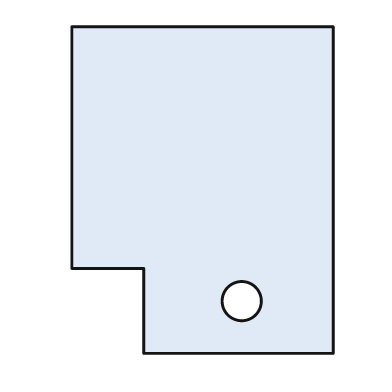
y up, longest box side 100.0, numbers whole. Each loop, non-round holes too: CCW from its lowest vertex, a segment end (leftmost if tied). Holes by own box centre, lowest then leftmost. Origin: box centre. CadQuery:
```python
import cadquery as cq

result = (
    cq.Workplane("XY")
    .moveTo(-18.0, -50.0)
    .lineTo(40.0, -50.0)
    .lineTo(40.0, 50.0)
    .lineTo(-40.0, 50.0)
    .lineTo(-40.0, -24.0)
    .lineTo(-18.0, -24.0)
    .close()
    .moveTo(12.0, -34.0)
    .circle(6.0)
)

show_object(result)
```